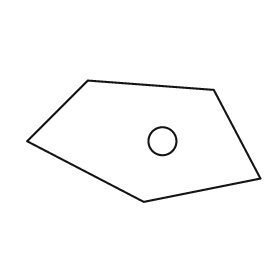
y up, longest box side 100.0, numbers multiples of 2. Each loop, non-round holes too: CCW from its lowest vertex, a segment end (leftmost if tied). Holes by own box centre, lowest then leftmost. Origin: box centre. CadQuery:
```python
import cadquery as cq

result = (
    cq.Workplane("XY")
    .moveTo(0.0, -26.0)
    .lineTo(50.0, -16.0)
    .lineTo(30.0, 22.0)
    .lineTo(-24.0, 26.0)
    .lineTo(-50.0, 0.0)
    .close()
    .moveTo(8.0, 0.0)
    .circle(6.0)
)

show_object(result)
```